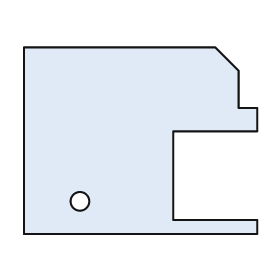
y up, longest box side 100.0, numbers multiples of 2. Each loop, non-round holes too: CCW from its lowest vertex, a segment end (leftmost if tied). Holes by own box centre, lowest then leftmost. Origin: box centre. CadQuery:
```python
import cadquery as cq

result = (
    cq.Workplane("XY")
    .moveTo(-50.0, -40.0)
    .lineTo(50.0, -40.0)
    .lineTo(50.0, -34.0)
    .lineTo(14.0, -34.0)
    .lineTo(14.0, 4.0)
    .lineTo(50.0, 4.0)
    .lineTo(50.0, 14.0)
    .lineTo(42.0, 14.0)
    .lineTo(42.0, 30.0)
    .lineTo(32.0, 40.0)
    .lineTo(-50.0, 40.0)
    .close()
    .moveTo(-26.0, -26.0)
    .circle(4.0)
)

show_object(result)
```